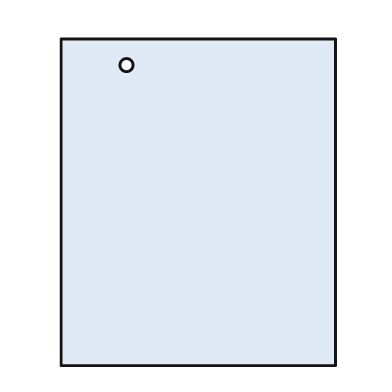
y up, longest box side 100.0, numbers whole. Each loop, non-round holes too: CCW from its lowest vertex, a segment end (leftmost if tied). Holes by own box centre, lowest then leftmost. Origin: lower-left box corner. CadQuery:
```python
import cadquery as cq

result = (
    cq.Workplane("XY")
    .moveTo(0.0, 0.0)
    .lineTo(84.0, 0.0)
    .lineTo(84.0, 100.0)
    .lineTo(0.0, 100.0)
    .close()
    .moveTo(20.0, 92.0)
    .circle(2.0)
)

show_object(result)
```